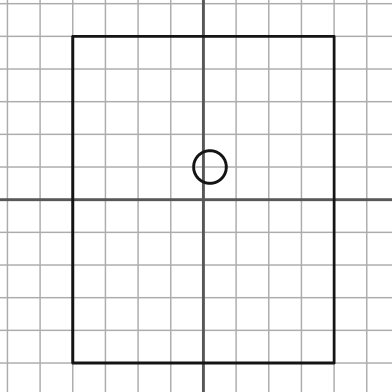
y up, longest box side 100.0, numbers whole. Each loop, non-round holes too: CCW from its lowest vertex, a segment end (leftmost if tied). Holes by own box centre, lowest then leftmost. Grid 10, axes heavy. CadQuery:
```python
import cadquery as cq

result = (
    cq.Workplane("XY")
    .moveTo(-40.0, -50.0)
    .lineTo(40.0, -50.0)
    .lineTo(40.0, 50.0)
    .lineTo(-40.0, 50.0)
    .close()
    .moveTo(2.0, 10.0)
    .circle(5.0)
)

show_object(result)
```